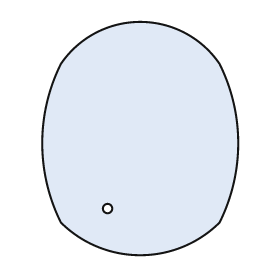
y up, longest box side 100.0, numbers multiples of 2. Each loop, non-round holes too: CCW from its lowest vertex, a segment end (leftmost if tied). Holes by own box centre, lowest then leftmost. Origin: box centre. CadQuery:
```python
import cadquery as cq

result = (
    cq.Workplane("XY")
    .moveTo(-34.0, -36.0)
    .threePointArc((0.0, -50.0), (34.0, -36.0))
    .threePointArc((42.0, -2.0), (34.0, 32.0))
    .threePointArc((0.0, 50.0), (-34.0, 32.0))
    .threePointArc((-42.0, -2.0), (-34.0, -36.0))
    .close()
    .moveTo(-14.0, -30.0)
    .circle(2.0)
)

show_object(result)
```